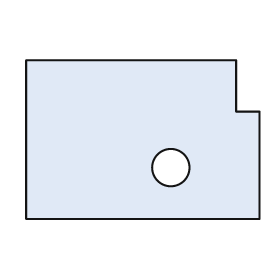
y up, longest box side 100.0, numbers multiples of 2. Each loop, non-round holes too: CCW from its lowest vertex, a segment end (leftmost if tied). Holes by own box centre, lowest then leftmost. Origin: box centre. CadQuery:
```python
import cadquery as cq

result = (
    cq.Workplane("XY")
    .moveTo(-50.0, -34.0)
    .lineTo(50.0, -34.0)
    .lineTo(50.0, 12.0)
    .lineTo(40.0, 12.0)
    .lineTo(40.0, 34.0)
    .lineTo(-50.0, 34.0)
    .close()
    .moveTo(12.0, -12.0)
    .circle(8.0)
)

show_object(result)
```